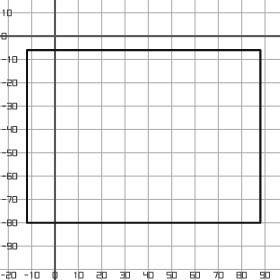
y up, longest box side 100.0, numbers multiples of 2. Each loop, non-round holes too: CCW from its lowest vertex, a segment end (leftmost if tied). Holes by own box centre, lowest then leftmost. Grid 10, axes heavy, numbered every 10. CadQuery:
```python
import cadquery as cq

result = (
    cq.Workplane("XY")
    .moveTo(-12.0, -80.0)
    .lineTo(88.0, -80.0)
    .lineTo(88.0, -6.0)
    .lineTo(-12.0, -6.0)
    .close()
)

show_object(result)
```